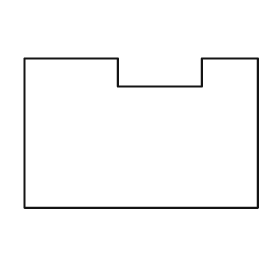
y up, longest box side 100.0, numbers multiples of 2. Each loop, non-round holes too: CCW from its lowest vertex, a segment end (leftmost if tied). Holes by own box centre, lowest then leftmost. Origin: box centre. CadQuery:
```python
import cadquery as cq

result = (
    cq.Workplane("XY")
    .moveTo(-50.0, -32.0)
    .lineTo(50.0, -32.0)
    .lineTo(50.0, 32.0)
    .lineTo(26.0, 32.0)
    .lineTo(26.0, 20.0)
    .lineTo(-10.0, 20.0)
    .lineTo(-10.0, 32.0)
    .lineTo(-50.0, 32.0)
    .close()
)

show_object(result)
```